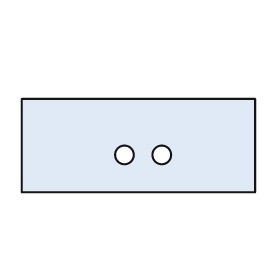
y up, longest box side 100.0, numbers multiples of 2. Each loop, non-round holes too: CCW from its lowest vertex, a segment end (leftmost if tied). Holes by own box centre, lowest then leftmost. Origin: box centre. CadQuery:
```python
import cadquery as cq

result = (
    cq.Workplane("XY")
    .moveTo(-50.0, -20.0)
    .lineTo(50.0, -20.0)
    .lineTo(50.0, 20.0)
    .lineTo(-50.0, 20.0)
    .close()
    .moveTo(-6.0, -4.0)
    .circle(4.0)
    .moveTo(10.0, -4.0)
    .circle(4.0)
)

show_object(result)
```